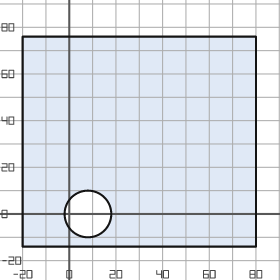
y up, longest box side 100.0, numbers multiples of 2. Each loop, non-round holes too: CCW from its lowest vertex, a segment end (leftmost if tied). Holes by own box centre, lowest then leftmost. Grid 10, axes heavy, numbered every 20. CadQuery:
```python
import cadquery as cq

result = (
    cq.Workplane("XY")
    .moveTo(-20.0, -14.0)
    .lineTo(80.0, -14.0)
    .lineTo(80.0, 76.0)
    .lineTo(-20.0, 76.0)
    .close()
    .moveTo(8.0, 0.0)
    .circle(10.0)
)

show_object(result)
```